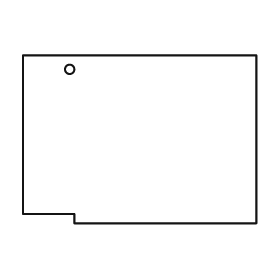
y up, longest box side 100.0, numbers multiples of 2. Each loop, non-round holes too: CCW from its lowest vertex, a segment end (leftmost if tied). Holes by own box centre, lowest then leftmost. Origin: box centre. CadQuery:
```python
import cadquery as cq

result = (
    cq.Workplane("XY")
    .moveTo(-28.0, -36.0)
    .lineTo(50.0, -36.0)
    .lineTo(50.0, 36.0)
    .lineTo(-50.0, 36.0)
    .lineTo(-50.0, -32.0)
    .lineTo(-28.0, -32.0)
    .close()
    .moveTo(-30.0, 30.0)
    .circle(2.0)
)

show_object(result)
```